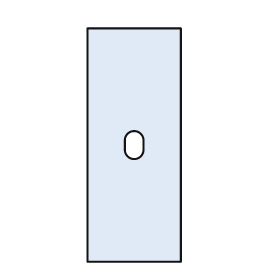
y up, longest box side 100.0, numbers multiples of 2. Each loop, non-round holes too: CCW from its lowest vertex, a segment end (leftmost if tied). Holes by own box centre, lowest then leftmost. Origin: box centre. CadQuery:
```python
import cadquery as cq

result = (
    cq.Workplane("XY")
    .moveTo(-20.0, -50.0)
    .lineTo(20.0, -50.0)
    .lineTo(20.0, 50.0)
    .lineTo(-20.0, 50.0)
    .close()
    .moveTo(-4.0, -2.0)
    .threePointArc((0.0, -6.0), (4.0, -2.0))
    .lineTo(4.0, 2.0)
    .threePointArc((0.0, 6.0), (-4.0, 2.0))
    .close()
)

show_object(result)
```